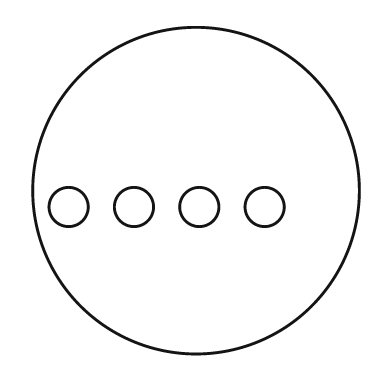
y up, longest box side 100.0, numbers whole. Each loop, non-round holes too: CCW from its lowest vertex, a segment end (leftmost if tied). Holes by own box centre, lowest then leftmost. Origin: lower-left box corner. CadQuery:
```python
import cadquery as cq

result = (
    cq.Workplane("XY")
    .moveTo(50.0, 50.0)
    .circle(50.0)
    .moveTo(11.0, 45.0)
    .circle(6.0)
    .moveTo(31.0, 45.0)
    .circle(6.0)
    .moveTo(51.0, 45.0)
    .circle(6.0)
    .moveTo(71.0, 45.0)
    .circle(6.0)
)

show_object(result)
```